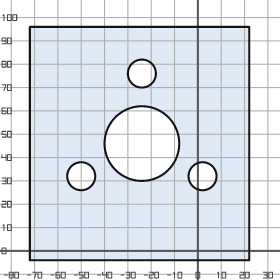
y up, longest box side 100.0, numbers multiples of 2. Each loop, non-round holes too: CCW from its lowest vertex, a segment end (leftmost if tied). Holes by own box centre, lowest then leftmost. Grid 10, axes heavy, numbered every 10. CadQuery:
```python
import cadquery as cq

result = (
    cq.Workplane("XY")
    .moveTo(-72.0, -4.0)
    .lineTo(22.0, -4.0)
    .lineTo(22.0, 96.0)
    .lineTo(-72.0, 96.0)
    .close()
    .moveTo(-50.0, 32.0)
    .circle(6.0)
    .moveTo(2.0, 32.0)
    .circle(6.0)
    .moveTo(-24.0, 46.0)
    .circle(16.0)
    .moveTo(-24.0, 76.0)
    .circle(6.0)
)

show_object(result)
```